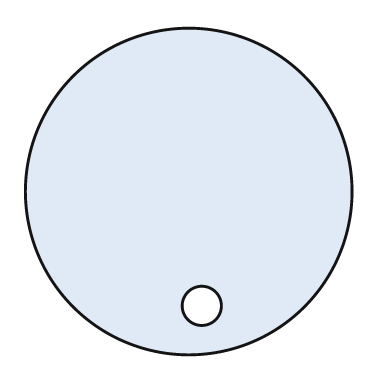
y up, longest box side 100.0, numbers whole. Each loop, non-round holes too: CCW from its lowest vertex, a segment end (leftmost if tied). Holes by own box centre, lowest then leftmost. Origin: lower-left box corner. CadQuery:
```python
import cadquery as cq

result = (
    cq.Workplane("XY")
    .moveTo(50.0, 50.0)
    .circle(50.0)
    .moveTo(54.0, 15.0)
    .circle(6.0)
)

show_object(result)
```